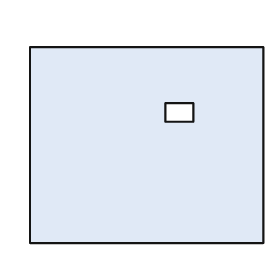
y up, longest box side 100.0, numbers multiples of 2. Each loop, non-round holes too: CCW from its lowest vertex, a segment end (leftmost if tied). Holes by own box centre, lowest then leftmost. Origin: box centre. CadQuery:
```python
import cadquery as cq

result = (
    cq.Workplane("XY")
    .moveTo(-50.0, -42.0)
    .lineTo(50.0, -42.0)
    .lineTo(50.0, 42.0)
    .lineTo(-50.0, 42.0)
    .close()
    .moveTo(8.0, 10.0)
    .lineTo(20.0, 10.0)
    .lineTo(20.0, 18.0)
    .lineTo(8.0, 18.0)
    .close()
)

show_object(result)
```